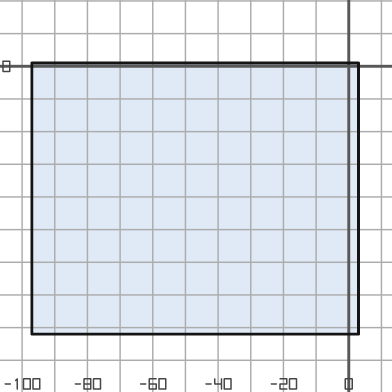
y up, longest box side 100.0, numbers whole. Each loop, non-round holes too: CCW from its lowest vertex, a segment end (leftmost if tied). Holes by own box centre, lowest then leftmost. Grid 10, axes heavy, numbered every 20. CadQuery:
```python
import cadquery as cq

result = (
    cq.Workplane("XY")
    .moveTo(-97.0, -82.0)
    .lineTo(3.0, -82.0)
    .lineTo(3.0, 1.0)
    .lineTo(-97.0, 1.0)
    .close()
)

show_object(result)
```